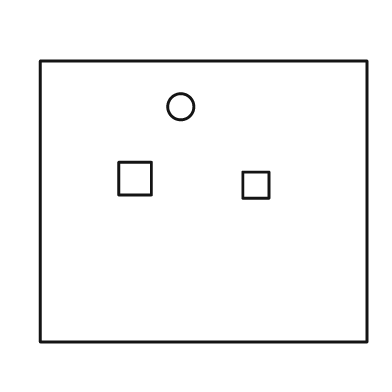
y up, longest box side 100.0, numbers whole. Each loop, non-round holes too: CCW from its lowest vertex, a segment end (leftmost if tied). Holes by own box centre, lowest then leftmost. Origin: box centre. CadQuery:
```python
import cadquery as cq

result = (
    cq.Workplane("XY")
    .moveTo(-50.0, -43.0)
    .lineTo(50.0, -43.0)
    .lineTo(50.0, 43.0)
    .lineTo(-50.0, 43.0)
    .close()
    .moveTo(12.0, 1.0)
    .lineTo(20.0, 1.0)
    .lineTo(20.0, 9.0)
    .lineTo(12.0, 9.0)
    .close()
    .moveTo(-26.0, 2.0)
    .lineTo(-16.0, 2.0)
    .lineTo(-16.0, 12.0)
    .lineTo(-26.0, 12.0)
    .close()
    .moveTo(-7.0, 29.0)
    .circle(4.0)
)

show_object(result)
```